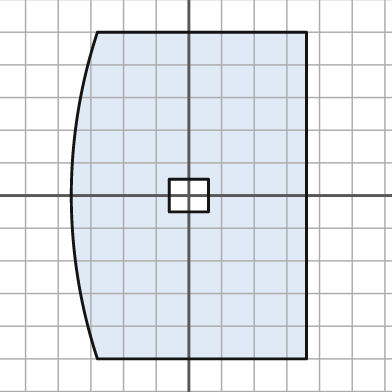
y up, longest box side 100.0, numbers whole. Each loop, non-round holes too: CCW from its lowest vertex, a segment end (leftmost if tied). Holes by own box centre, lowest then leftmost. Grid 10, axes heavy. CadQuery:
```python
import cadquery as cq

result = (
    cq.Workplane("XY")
    .moveTo(-28.0, -50.0)
    .lineTo(36.0, -50.0)
    .lineTo(36.0, 50.0)
    .lineTo(-28.0, 50.0)
    .threePointArc((-36.0, 0.0), (-28.0, -50.0))
    .close()
    .moveTo(-6.0, -5.0)
    .lineTo(6.0, -5.0)
    .lineTo(6.0, 5.0)
    .lineTo(-6.0, 5.0)
    .close()
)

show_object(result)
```